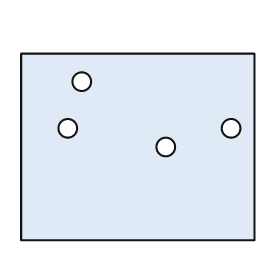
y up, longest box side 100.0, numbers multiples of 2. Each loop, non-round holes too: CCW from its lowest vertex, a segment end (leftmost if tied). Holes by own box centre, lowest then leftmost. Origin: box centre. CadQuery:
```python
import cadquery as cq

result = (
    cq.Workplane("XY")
    .moveTo(-50.0, -40.0)
    .lineTo(50.0, -40.0)
    .lineTo(50.0, 40.0)
    .lineTo(-50.0, 40.0)
    .close()
    .moveTo(12.0, 0.0)
    .circle(4.0)
    .moveTo(-30.0, 8.0)
    .circle(4.0)
    .moveTo(40.0, 8.0)
    .circle(4.0)
    .moveTo(-24.0, 28.0)
    .circle(4.0)
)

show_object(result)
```